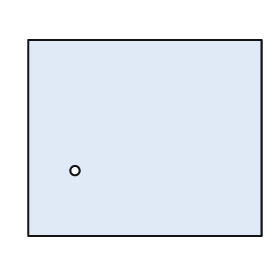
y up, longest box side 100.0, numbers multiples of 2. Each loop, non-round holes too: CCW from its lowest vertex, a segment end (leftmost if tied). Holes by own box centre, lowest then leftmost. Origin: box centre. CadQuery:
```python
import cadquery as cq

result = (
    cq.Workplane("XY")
    .moveTo(-50.0, -42.0)
    .lineTo(50.0, -42.0)
    .lineTo(50.0, 42.0)
    .lineTo(-50.0, 42.0)
    .close()
    .moveTo(-30.0, -14.0)
    .circle(2.0)
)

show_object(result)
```